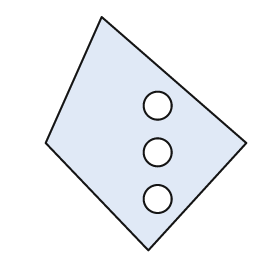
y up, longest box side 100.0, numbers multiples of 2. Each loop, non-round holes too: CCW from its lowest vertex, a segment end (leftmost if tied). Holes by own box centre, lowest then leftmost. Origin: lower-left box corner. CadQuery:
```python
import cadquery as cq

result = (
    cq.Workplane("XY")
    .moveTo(44.0, 0.0)
    .lineTo(86.0, 46.0)
    .lineTo(24.0, 100.0)
    .lineTo(0.0, 46.0)
    .close()
    .moveTo(48.0, 22.0)
    .circle(6.0)
    .moveTo(48.0, 42.0)
    .circle(6.0)
    .moveTo(48.0, 62.0)
    .circle(6.0)
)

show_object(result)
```